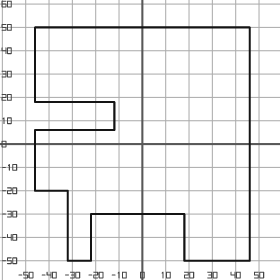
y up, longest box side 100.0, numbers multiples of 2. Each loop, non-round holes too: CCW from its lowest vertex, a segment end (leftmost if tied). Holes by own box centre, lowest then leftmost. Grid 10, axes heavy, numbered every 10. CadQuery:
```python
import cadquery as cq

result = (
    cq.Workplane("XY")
    .moveTo(-32.0, -50.0)
    .lineTo(-22.0, -50.0)
    .lineTo(-22.0, -30.0)
    .lineTo(18.0, -30.0)
    .lineTo(18.0, -50.0)
    .lineTo(46.0, -50.0)
    .lineTo(46.0, 50.0)
    .lineTo(-46.0, 50.0)
    .lineTo(-46.0, 18.0)
    .lineTo(-12.0, 18.0)
    .lineTo(-12.0, 6.0)
    .lineTo(-46.0, 6.0)
    .lineTo(-46.0, -20.0)
    .lineTo(-32.0, -20.0)
    .close()
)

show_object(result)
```